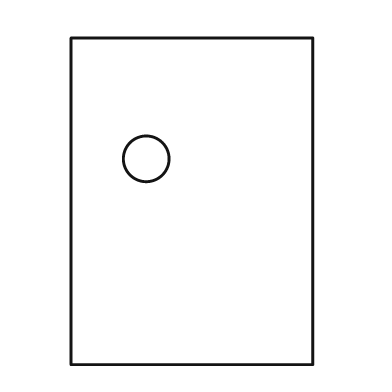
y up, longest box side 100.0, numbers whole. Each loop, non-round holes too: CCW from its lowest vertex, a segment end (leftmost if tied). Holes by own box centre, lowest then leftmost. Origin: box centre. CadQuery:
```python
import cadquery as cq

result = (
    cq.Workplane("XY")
    .moveTo(-37.0, -50.0)
    .lineTo(37.0, -50.0)
    .lineTo(37.0, 50.0)
    .lineTo(-37.0, 50.0)
    .close()
    .moveTo(-14.0, 13.0)
    .circle(7.0)
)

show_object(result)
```